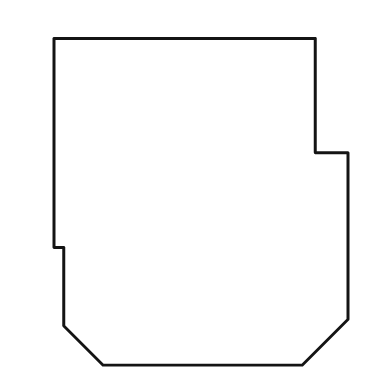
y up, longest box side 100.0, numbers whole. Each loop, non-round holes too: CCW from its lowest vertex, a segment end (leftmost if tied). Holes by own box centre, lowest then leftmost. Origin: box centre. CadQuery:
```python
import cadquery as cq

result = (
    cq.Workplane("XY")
    .moveTo(-30.0, -50.0)
    .lineTo(31.0, -50.0)
    .lineTo(45.0, -36.0)
    .lineTo(45.0, 15.0)
    .lineTo(35.0, 15.0)
    .lineTo(35.0, 50.0)
    .lineTo(-45.0, 50.0)
    .lineTo(-45.0, -14.0)
    .lineTo(-42.0, -14.0)
    .lineTo(-42.0, -38.0)
    .close()
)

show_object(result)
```